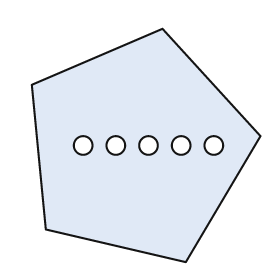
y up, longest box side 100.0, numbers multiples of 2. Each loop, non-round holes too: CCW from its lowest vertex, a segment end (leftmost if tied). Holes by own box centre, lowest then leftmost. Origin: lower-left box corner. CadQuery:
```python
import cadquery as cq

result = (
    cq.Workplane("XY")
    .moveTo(66.0, 0.0)
    .lineTo(98.0, 54.0)
    .lineTo(56.0, 100.0)
    .lineTo(0.0, 76.0)
    .lineTo(6.0, 14.0)
    .close()
    .moveTo(22.0, 50.0)
    .circle(4.0)
    .moveTo(36.0, 50.0)
    .circle(4.0)
    .moveTo(50.0, 50.0)
    .circle(4.0)
    .moveTo(64.0, 50.0)
    .circle(4.0)
    .moveTo(78.0, 50.0)
    .circle(4.0)
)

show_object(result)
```